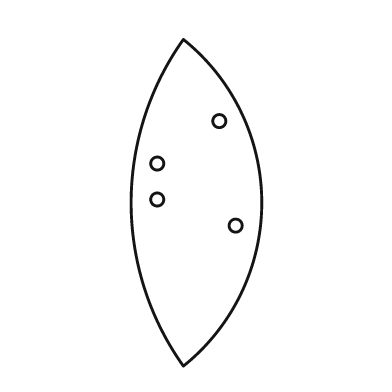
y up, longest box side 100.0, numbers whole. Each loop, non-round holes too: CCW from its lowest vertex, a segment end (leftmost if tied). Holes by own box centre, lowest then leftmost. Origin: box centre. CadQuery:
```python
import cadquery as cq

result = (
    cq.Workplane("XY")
    .moveTo(-4.0, -50.0)
    .threePointArc((20.0, 0.0), (-4.0, 50.0))
    .threePointArc((-20.0, 0.0), (-4.0, -50.0))
    .close()
    .moveTo(12.0, -7.0)
    .circle(2.0)
    .moveTo(-12.0, 1.0)
    .circle(2.0)
    .moveTo(-12.0, 12.0)
    .circle(2.0)
    .moveTo(7.0, 25.0)
    .circle(2.0)
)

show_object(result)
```